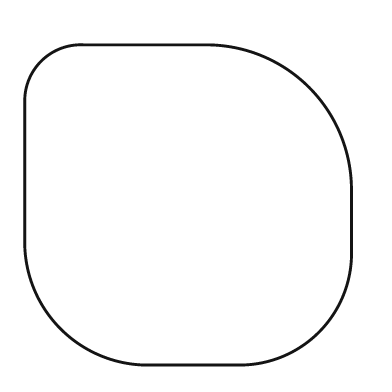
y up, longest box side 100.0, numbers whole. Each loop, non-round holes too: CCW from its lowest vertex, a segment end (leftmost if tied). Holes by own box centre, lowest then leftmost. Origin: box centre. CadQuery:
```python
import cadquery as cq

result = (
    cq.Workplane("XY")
    .moveTo(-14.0, -49.0)
    .lineTo(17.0, -49.0)
    .threePointArc((40.0, -39.0), (50.0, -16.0))
    .lineTo(50.0, 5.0)
    .threePointArc((37.0, 36.0), (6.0, 49.0))
    .lineTo(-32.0, 49.0)
    .threePointArc((-45.0, 44.0), (-50.0, 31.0))
    .lineTo(-50.0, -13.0)
    .threePointArc((-39.0, -38.0), (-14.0, -49.0))
    .close()
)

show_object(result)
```